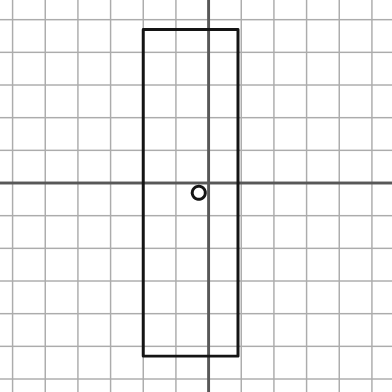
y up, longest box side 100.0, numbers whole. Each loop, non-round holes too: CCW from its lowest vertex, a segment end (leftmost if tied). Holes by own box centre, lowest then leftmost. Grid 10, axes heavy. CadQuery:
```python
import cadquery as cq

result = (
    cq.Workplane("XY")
    .moveTo(-20.0, -53.0)
    .lineTo(9.0, -53.0)
    .lineTo(9.0, 47.0)
    .lineTo(-20.0, 47.0)
    .close()
    .moveTo(-3.0, -3.0)
    .circle(2.0)
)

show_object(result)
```